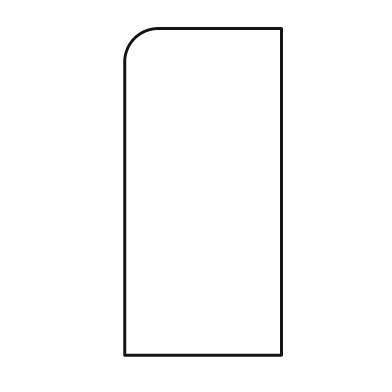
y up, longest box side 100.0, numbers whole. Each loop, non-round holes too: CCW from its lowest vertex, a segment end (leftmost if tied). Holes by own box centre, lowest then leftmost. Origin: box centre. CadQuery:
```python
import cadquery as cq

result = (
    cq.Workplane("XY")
    .moveTo(-24.0, -50.0)
    .lineTo(24.0, -50.0)
    .lineTo(24.0, 50.0)
    .lineTo(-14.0, 50.0)
    .threePointArc((-21.0, 47.0), (-24.0, 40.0))
    .close()
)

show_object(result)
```